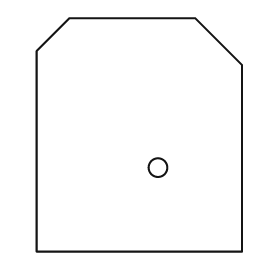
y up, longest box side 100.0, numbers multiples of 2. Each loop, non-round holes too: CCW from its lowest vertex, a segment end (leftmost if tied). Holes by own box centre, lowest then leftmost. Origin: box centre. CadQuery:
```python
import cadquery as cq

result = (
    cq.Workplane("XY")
    .moveTo(-44.0, -50.0)
    .lineTo(44.0, -50.0)
    .lineTo(44.0, 30.0)
    .lineTo(24.0, 50.0)
    .lineTo(-30.0, 50.0)
    .lineTo(-44.0, 36.0)
    .close()
    .moveTo(8.0, -14.0)
    .circle(4.0)
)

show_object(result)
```